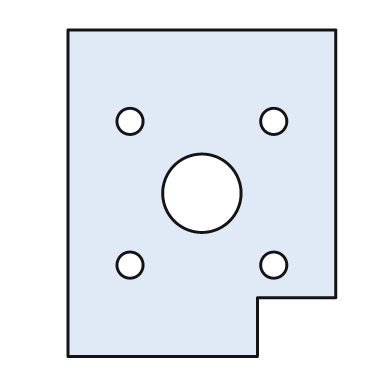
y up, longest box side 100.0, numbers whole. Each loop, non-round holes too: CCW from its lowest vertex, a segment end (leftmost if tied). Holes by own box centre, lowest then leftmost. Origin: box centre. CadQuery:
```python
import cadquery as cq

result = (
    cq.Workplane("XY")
    .moveTo(-41.0, -50.0)
    .lineTo(17.0, -50.0)
    .lineTo(17.0, -32.0)
    .lineTo(41.0, -32.0)
    .lineTo(41.0, 50.0)
    .lineTo(-41.0, 50.0)
    .close()
    .moveTo(-22.0, -22.0)
    .circle(4.0)
    .moveTo(22.0, -22.0)
    .circle(4.0)
    .moveTo(0.0, 0.0)
    .circle(12.0)
    .moveTo(-22.0, 22.0)
    .circle(4.0)
    .moveTo(22.0, 22.0)
    .circle(4.0)
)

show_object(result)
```